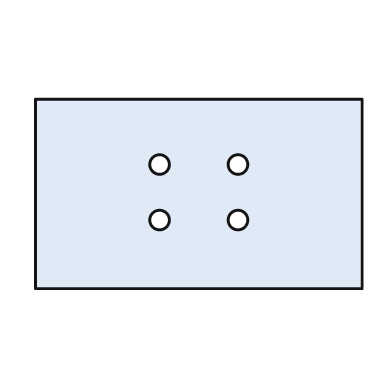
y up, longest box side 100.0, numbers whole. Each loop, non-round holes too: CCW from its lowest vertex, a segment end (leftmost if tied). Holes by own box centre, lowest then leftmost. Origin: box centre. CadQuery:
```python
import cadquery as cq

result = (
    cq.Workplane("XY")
    .moveTo(-50.0, -29.0)
    .lineTo(50.0, -29.0)
    .lineTo(50.0, 29.0)
    .lineTo(-50.0, 29.0)
    .close()
    .moveTo(-12.0, -8.0)
    .circle(3.0)
    .moveTo(12.0, -8.0)
    .circle(3.0)
    .moveTo(-12.0, 9.0)
    .circle(3.0)
    .moveTo(12.0, 9.0)
    .circle(3.0)
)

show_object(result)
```